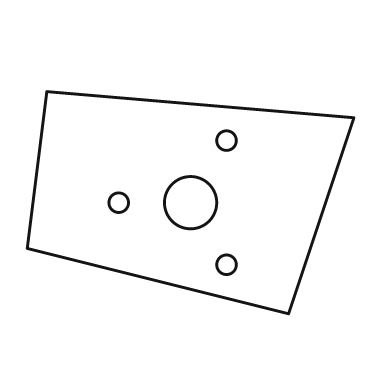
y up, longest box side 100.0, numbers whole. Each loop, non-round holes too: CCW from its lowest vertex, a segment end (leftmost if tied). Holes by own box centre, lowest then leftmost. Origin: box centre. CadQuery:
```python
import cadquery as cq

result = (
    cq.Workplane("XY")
    .moveTo(30.0, -34.0)
    .lineTo(50.0, 26.0)
    .lineTo(-44.0, 34.0)
    .lineTo(-50.0, -14.0)
    .close()
    .moveTo(11.0, -19.0)
    .circle(3.0)
    .moveTo(-22.0, 0.0)
    .circle(3.0)
    .moveTo(0.0, 0.0)
    .circle(8.0)
    .moveTo(11.0, 19.0)
    .circle(3.0)
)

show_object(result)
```